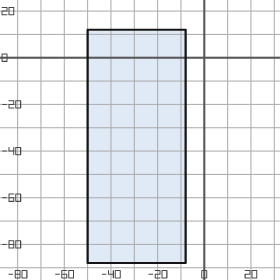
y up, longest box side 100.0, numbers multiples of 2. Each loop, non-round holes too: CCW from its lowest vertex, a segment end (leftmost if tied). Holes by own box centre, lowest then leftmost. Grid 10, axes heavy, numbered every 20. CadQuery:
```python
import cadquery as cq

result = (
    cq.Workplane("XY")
    .moveTo(-50.0, -88.0)
    .lineTo(-8.0, -88.0)
    .lineTo(-8.0, 12.0)
    .lineTo(-50.0, 12.0)
    .close()
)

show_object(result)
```